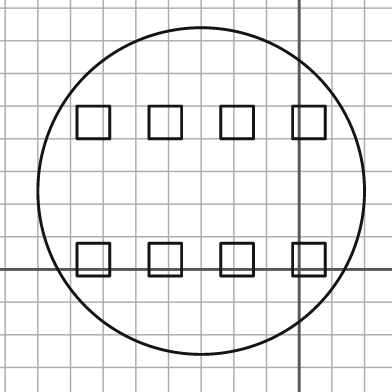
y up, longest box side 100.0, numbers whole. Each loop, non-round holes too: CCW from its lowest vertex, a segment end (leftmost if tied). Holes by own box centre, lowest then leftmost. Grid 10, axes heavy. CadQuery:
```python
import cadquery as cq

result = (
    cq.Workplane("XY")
    .moveTo(-30.0, 24.0)
    .circle(50.0)
    .moveTo(-68.0, -2.0)
    .lineTo(-58.0, -2.0)
    .lineTo(-58.0, 8.0)
    .lineTo(-68.0, 8.0)
    .close()
    .moveTo(-46.0, -2.0)
    .lineTo(-36.0, -2.0)
    .lineTo(-36.0, 8.0)
    .lineTo(-46.0, 8.0)
    .close()
    .moveTo(-24.0, -2.0)
    .lineTo(-14.0, -2.0)
    .lineTo(-14.0, 8.0)
    .lineTo(-24.0, 8.0)
    .close()
    .moveTo(-2.0, -2.0)
    .lineTo(8.0, -2.0)
    .lineTo(8.0, 8.0)
    .lineTo(-2.0, 8.0)
    .close()
    .moveTo(-68.0, 40.0)
    .lineTo(-58.0, 40.0)
    .lineTo(-58.0, 50.0)
    .lineTo(-68.0, 50.0)
    .close()
    .moveTo(-46.0, 40.0)
    .lineTo(-36.0, 40.0)
    .lineTo(-36.0, 50.0)
    .lineTo(-46.0, 50.0)
    .close()
    .moveTo(-24.0, 40.0)
    .lineTo(-14.0, 40.0)
    .lineTo(-14.0, 50.0)
    .lineTo(-24.0, 50.0)
    .close()
    .moveTo(-2.0, 40.0)
    .lineTo(8.0, 40.0)
    .lineTo(8.0, 50.0)
    .lineTo(-2.0, 50.0)
    .close()
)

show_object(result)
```